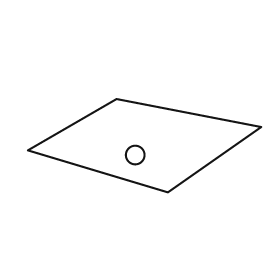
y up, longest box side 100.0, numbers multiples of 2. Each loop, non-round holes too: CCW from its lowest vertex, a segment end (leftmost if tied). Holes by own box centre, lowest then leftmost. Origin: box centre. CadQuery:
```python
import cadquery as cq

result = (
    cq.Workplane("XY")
    .moveTo(10.0, -20.0)
    .lineTo(50.0, 8.0)
    .lineTo(-12.0, 20.0)
    .lineTo(-50.0, -2.0)
    .close()
    .moveTo(-4.0, -4.0)
    .circle(4.0)
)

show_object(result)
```